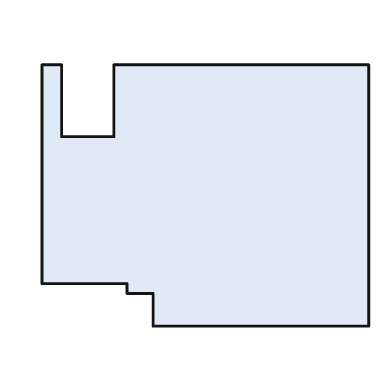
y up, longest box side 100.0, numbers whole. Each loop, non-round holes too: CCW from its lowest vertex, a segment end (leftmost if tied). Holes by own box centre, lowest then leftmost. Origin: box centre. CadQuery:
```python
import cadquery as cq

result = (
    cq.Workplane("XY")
    .moveTo(-16.0, -40.0)
    .lineTo(50.0, -40.0)
    .lineTo(50.0, 40.0)
    .lineTo(-28.0, 40.0)
    .lineTo(-28.0, 18.0)
    .lineTo(-44.0, 18.0)
    .lineTo(-44.0, 40.0)
    .lineTo(-50.0, 40.0)
    .lineTo(-50.0, -27.0)
    .lineTo(-24.0, -27.0)
    .lineTo(-24.0, -30.0)
    .lineTo(-16.0, -30.0)
    .close()
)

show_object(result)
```